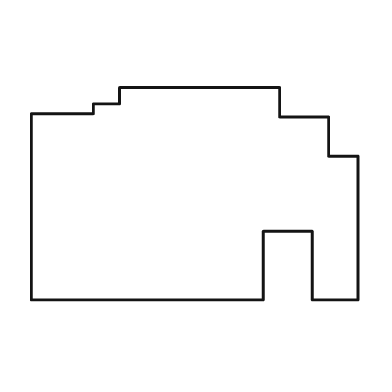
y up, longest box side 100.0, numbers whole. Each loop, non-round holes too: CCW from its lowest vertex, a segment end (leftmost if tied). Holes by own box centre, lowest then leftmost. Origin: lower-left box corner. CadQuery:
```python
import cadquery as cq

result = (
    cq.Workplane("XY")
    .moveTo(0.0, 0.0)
    .lineTo(71.0, 0.0)
    .lineTo(71.0, 21.0)
    .lineTo(86.0, 21.0)
    .lineTo(86.0, 0.0)
    .lineTo(100.0, 0.0)
    .lineTo(100.0, 44.0)
    .lineTo(91.0, 44.0)
    .lineTo(91.0, 56.0)
    .lineTo(76.0, 56.0)
    .lineTo(76.0, 65.0)
    .lineTo(27.0, 65.0)
    .lineTo(27.0, 60.0)
    .lineTo(19.0, 60.0)
    .lineTo(19.0, 57.0)
    .lineTo(0.0, 57.0)
    .close()
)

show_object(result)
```